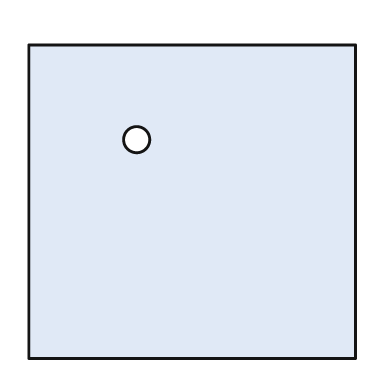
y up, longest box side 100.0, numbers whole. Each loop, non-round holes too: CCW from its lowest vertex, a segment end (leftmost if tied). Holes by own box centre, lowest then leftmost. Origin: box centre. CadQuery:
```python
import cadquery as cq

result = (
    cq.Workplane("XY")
    .moveTo(-50.0, -48.0)
    .lineTo(50.0, -48.0)
    .lineTo(50.0, 48.0)
    .lineTo(-50.0, 48.0)
    .close()
    .moveTo(-17.0, 19.0)
    .circle(4.0)
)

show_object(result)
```